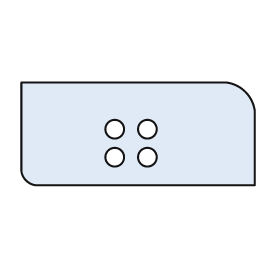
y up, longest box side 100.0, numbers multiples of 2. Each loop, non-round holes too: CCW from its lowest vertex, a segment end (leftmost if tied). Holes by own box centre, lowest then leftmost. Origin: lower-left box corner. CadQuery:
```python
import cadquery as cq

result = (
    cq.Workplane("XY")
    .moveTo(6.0, 0.0)
    .lineTo(100.0, 0.0)
    .lineTo(100.0, 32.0)
    .threePointArc((96.0, 40.0), (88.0, 44.0))
    .lineTo(0.0, 44.0)
    .lineTo(0.0, 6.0)
    .threePointArc((2.0, 2.0), (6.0, 0.0))
    .close()
    .moveTo(40.0, 12.0)
    .circle(4.0)
    .moveTo(54.0, 12.0)
    .circle(4.0)
    .moveTo(40.0, 24.0)
    .circle(4.0)
    .moveTo(54.0, 24.0)
    .circle(4.0)
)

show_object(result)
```